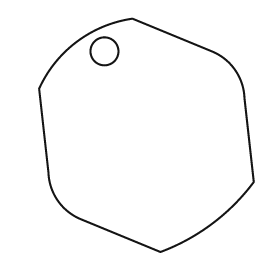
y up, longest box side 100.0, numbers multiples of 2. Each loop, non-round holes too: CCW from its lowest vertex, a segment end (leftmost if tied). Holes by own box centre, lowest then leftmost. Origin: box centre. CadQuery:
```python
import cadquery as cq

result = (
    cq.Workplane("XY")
    .moveTo(6.0, -50.0)
    .threePointArc((28.0, -38.0), (46.0, -20.0))
    .lineTo(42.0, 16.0)
    .threePointArc((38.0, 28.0), (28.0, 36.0))
    .lineTo(-6.0, 50.0)
    .threePointArc((-30.0, 40.0), (-46.0, 20.0))
    .lineTo(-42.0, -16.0)
    .threePointArc((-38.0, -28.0), (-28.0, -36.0))
    .close()
    .moveTo(-18.0, 36.0)
    .circle(6.0)
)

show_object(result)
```